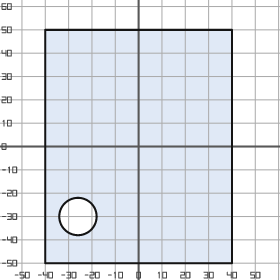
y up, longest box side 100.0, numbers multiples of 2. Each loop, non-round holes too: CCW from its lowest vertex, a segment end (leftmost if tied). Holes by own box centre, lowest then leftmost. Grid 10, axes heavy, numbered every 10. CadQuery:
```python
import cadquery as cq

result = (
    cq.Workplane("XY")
    .moveTo(-40.0, -50.0)
    .lineTo(40.0, -50.0)
    .lineTo(40.0, 50.0)
    .lineTo(-40.0, 50.0)
    .close()
    .moveTo(-26.0, -30.0)
    .circle(8.0)
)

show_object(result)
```